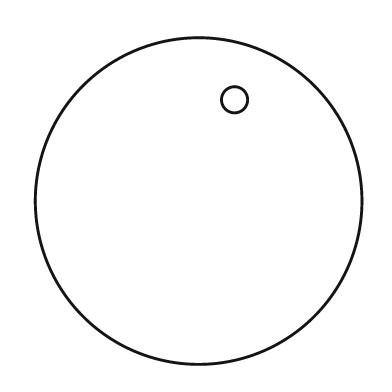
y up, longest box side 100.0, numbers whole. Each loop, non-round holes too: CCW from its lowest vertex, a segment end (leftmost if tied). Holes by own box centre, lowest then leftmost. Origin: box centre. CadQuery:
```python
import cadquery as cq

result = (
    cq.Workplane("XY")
    .moveTo(0.0, 0.0)
    .circle(50.0)
    .moveTo(11.0, 31.0)
    .circle(4.0)
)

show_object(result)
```